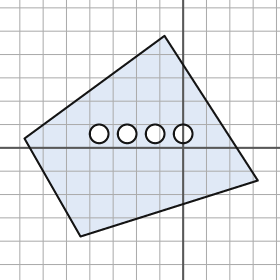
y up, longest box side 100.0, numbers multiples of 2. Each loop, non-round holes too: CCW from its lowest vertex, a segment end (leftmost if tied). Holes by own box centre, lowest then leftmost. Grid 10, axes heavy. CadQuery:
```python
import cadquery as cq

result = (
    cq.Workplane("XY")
    .moveTo(-44.0, -38.0)
    .lineTo(32.0, -14.0)
    .lineTo(-8.0, 48.0)
    .lineTo(-68.0, 4.0)
    .close()
    .moveTo(-36.0, 6.0)
    .circle(4.0)
    .moveTo(-24.0, 6.0)
    .circle(4.0)
    .moveTo(-12.0, 6.0)
    .circle(4.0)
    .moveTo(0.0, 6.0)
    .circle(4.0)
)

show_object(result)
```